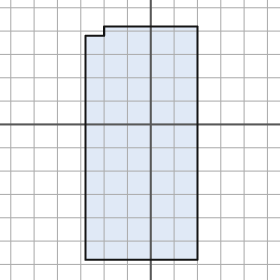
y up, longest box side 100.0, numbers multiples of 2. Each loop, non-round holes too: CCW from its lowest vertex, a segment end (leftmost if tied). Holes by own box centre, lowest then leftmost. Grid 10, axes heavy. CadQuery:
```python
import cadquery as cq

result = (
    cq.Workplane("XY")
    .moveTo(-28.0, -58.0)
    .lineTo(20.0, -58.0)
    .lineTo(20.0, 42.0)
    .lineTo(-20.0, 42.0)
    .lineTo(-20.0, 38.0)
    .lineTo(-28.0, 38.0)
    .close()
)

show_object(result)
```